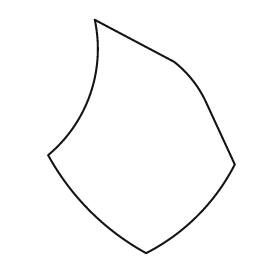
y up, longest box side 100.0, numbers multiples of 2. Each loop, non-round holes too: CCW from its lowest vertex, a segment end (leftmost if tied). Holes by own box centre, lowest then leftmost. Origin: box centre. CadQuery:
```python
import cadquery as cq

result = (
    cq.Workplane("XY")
    .moveTo(2.0, -50.0)
    .threePointArc((24.0, -34.0), (40.0, -12.0))
    .lineTo(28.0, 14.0)
    .threePointArc((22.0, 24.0), (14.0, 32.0))
    .lineTo(-20.0, 50.0)
    .threePointArc((-22.0, 18.0), (-40.0, -8.0))
    .threePointArc((-22.0, -32.0), (2.0, -50.0))
    .close()
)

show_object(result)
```